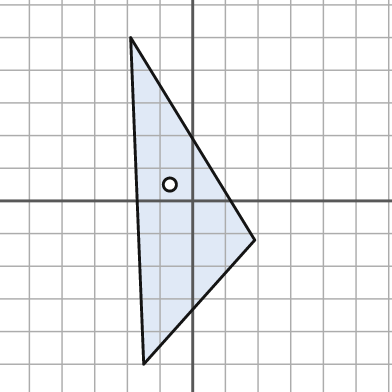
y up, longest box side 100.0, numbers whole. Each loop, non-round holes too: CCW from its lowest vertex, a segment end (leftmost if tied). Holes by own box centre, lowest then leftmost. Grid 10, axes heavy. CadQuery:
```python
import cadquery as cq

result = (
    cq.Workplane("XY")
    .moveTo(-15.0, -50.0)
    .lineTo(19.0, -12.0)
    .lineTo(-19.0, 50.0)
    .close()
    .moveTo(-7.0, 5.0)
    .circle(2.0)
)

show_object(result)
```